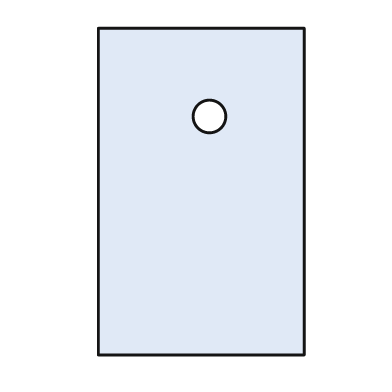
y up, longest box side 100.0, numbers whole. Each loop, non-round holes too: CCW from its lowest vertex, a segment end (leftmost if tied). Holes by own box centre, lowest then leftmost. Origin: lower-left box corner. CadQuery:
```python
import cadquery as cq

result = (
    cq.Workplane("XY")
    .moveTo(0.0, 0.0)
    .lineTo(63.0, 0.0)
    .lineTo(63.0, 100.0)
    .lineTo(0.0, 100.0)
    .close()
    .moveTo(34.0, 73.0)
    .circle(5.0)
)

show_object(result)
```